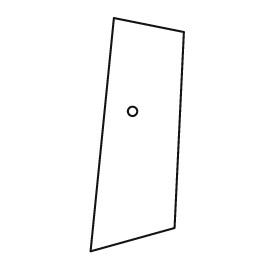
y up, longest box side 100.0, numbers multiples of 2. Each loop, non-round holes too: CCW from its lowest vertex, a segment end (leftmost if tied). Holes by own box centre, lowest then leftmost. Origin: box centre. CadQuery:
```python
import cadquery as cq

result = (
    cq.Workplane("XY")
    .moveTo(-20.0, -50.0)
    .lineTo(16.0, -40.0)
    .lineTo(20.0, 44.0)
    .lineTo(-10.0, 50.0)
    .close()
    .moveTo(-2.0, 10.0)
    .circle(2.0)
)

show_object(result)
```